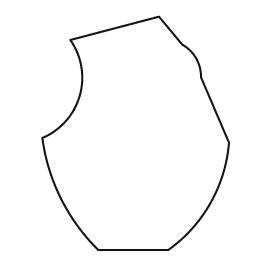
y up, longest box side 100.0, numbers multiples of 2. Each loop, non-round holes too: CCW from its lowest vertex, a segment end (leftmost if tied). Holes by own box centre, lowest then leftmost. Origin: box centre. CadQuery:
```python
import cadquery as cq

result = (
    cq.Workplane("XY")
    .moveTo(-16.0, -50.0)
    .lineTo(14.0, -50.0)
    .threePointArc((32.0, -30.0), (40.0, -4.0))
    .lineTo(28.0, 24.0)
    .threePointArc((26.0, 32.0), (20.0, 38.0))
    .lineTo(10.0, 50.0)
    .lineTo(-28.0, 40.0)
    .threePointArc((-24.0, 16.0), (-40.0, -2.0))
    .threePointArc((-32.0, -28.0), (-16.0, -50.0))
    .close()
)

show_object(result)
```